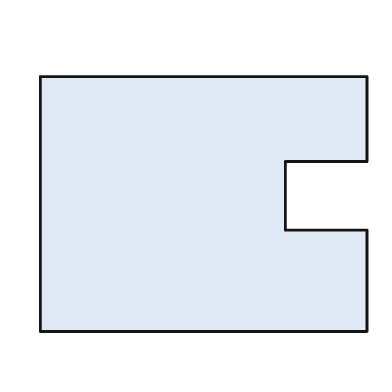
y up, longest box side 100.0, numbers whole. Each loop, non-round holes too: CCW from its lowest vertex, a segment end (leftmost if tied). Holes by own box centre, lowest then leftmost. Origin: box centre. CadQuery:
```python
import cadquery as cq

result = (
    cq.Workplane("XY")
    .moveTo(-50.0, -39.0)
    .lineTo(50.0, -39.0)
    .lineTo(50.0, -8.0)
    .lineTo(25.0, -8.0)
    .lineTo(25.0, 13.0)
    .lineTo(50.0, 13.0)
    .lineTo(50.0, 39.0)
    .lineTo(-50.0, 39.0)
    .close()
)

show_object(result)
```